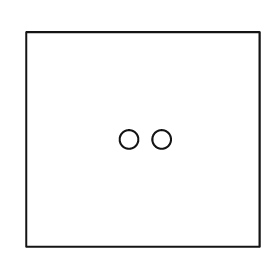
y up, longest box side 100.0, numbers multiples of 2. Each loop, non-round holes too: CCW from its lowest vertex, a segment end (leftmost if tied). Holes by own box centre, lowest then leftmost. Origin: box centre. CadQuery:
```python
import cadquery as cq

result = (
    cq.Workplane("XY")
    .moveTo(-50.0, -46.0)
    .lineTo(50.0, -46.0)
    .lineTo(50.0, 46.0)
    .lineTo(-50.0, 46.0)
    .close()
    .moveTo(-6.0, 0.0)
    .circle(4.0)
    .moveTo(8.0, 0.0)
    .circle(4.0)
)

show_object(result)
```